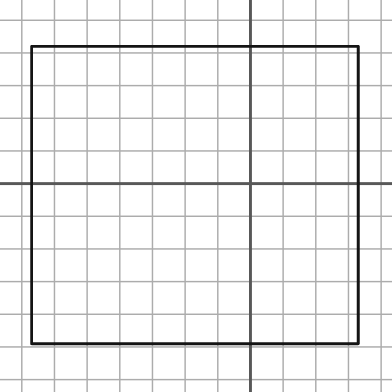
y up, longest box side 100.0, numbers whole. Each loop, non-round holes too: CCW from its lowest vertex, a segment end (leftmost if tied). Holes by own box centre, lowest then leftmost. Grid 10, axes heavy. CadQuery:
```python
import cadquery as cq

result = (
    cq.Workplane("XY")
    .moveTo(-67.0, -49.0)
    .lineTo(33.0, -49.0)
    .lineTo(33.0, 42.0)
    .lineTo(-67.0, 42.0)
    .close()
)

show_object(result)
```